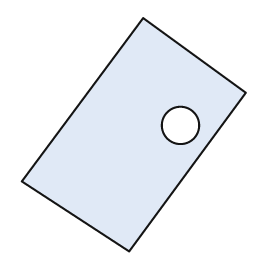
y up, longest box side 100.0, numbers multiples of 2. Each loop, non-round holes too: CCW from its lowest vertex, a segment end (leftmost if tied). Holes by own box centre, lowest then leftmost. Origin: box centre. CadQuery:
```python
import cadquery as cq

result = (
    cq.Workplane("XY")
    .moveTo(-2.0, -50.0)
    .lineTo(48.0, 18.0)
    .lineTo(4.0, 50.0)
    .lineTo(-48.0, -20.0)
    .close()
    .moveTo(20.0, 4.0)
    .circle(8.0)
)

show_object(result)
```